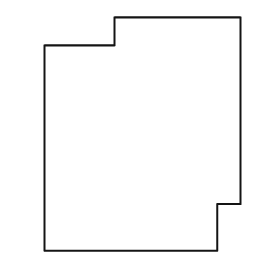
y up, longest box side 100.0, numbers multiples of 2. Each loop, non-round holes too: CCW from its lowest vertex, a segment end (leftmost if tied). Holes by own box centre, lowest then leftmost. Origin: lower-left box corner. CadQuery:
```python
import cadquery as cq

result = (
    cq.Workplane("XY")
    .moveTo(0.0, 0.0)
    .lineTo(74.0, 0.0)
    .lineTo(74.0, 20.0)
    .lineTo(84.0, 20.0)
    .lineTo(84.0, 100.0)
    .lineTo(30.0, 100.0)
    .lineTo(30.0, 88.0)
    .lineTo(0.0, 88.0)
    .close()
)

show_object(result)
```